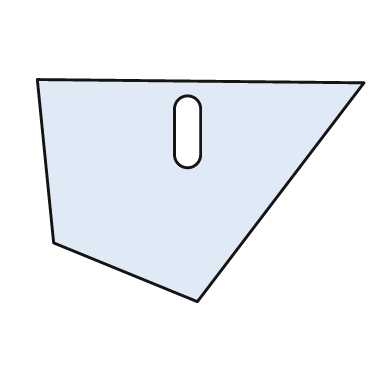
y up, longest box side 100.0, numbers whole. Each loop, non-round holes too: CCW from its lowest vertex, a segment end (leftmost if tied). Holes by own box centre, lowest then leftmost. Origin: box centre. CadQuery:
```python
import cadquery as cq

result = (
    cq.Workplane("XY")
    .moveTo(-1.0, -34.0)
    .lineTo(50.0, 33.0)
    .lineTo(-50.0, 34.0)
    .lineTo(-45.0, -16.0)
    .close()
    .moveTo(-8.0, 11.0)
    .threePointArc((-4.0, 7.0), (0.0, 11.0))
    .lineTo(0.0, 25.0)
    .threePointArc((-4.0, 29.0), (-8.0, 25.0))
    .close()
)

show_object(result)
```